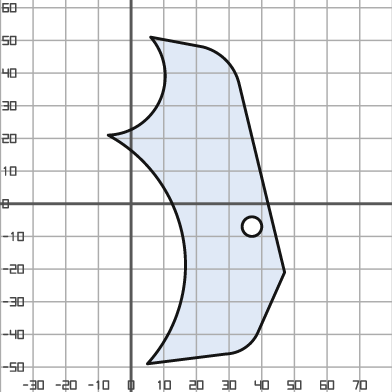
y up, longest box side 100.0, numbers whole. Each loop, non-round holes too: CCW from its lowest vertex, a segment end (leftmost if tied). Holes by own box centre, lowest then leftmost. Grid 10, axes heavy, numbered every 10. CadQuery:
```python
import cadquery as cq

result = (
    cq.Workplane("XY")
    .moveTo(5.0, -49.0)
    .lineTo(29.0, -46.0)
    .threePointArc((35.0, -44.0), (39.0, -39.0))
    .lineTo(47.0, -21.0)
    .lineTo(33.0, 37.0)
    .threePointArc((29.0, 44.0), (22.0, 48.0))
    .lineTo(6.0, 51.0)
    .threePointArc((9.0, 32.0), (-7.0, 21.0))
    .threePointArc((16.0, -11.0), (5.0, -49.0))
    .close()
    .moveTo(37.0, -7.0)
    .circle(3.0)
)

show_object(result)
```